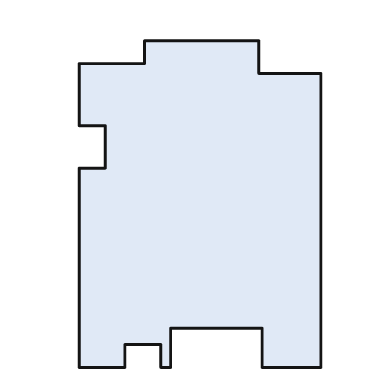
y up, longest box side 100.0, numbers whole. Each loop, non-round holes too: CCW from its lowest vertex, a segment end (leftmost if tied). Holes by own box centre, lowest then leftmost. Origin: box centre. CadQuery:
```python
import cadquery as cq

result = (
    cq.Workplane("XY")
    .moveTo(-37.0, -50.0)
    .lineTo(-23.0, -50.0)
    .lineTo(-23.0, -43.0)
    .lineTo(-12.0, -43.0)
    .lineTo(-12.0, -50.0)
    .lineTo(-9.0, -50.0)
    .lineTo(-9.0, -38.0)
    .lineTo(19.0, -38.0)
    .lineTo(19.0, -50.0)
    .lineTo(37.0, -50.0)
    .lineTo(37.0, 40.0)
    .lineTo(18.0, 40.0)
    .lineTo(18.0, 50.0)
    .lineTo(-17.0, 50.0)
    .lineTo(-17.0, 43.0)
    .lineTo(-37.0, 43.0)
    .lineTo(-37.0, 24.0)
    .lineTo(-29.0, 24.0)
    .lineTo(-29.0, 11.0)
    .lineTo(-37.0, 11.0)
    .close()
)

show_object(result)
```